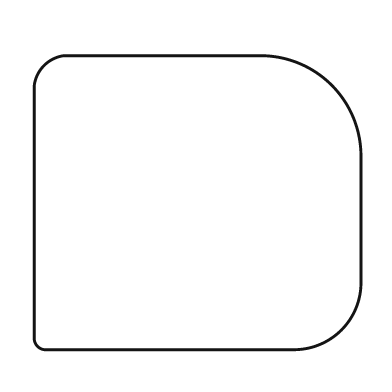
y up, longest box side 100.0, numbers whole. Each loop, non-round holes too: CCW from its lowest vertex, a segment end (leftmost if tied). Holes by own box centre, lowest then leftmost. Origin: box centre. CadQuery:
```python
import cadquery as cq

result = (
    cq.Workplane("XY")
    .moveTo(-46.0, -45.0)
    .lineTo(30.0, -45.0)
    .threePointArc((44.0, -39.0), (50.0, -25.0))
    .lineTo(50.0, 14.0)
    .threePointArc((41.0, 36.0), (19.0, 45.0))
    .lineTo(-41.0, 45.0)
    .threePointArc((-47.0, 42.0), (-50.0, 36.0))
    .lineTo(-50.0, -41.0)
    .threePointArc((-49.0, -44.0), (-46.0, -45.0))
    .close()
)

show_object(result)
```